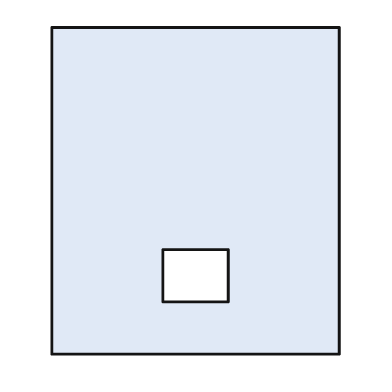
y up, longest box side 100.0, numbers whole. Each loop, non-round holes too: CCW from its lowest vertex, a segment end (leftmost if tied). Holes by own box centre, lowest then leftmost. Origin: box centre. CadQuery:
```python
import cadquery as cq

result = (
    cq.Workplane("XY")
    .moveTo(-44.0, -50.0)
    .lineTo(44.0, -50.0)
    .lineTo(44.0, 50.0)
    .lineTo(-44.0, 50.0)
    .close()
    .moveTo(-10.0, -34.0)
    .lineTo(10.0, -34.0)
    .lineTo(10.0, -18.0)
    .lineTo(-10.0, -18.0)
    .close()
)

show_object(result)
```